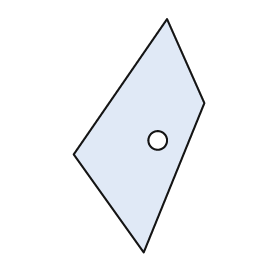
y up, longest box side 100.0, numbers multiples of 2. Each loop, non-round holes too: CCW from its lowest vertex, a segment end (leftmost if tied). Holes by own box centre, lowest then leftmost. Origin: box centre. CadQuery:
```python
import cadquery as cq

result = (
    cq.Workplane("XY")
    .moveTo(2.0, -50.0)
    .lineTo(28.0, 14.0)
    .lineTo(12.0, 50.0)
    .lineTo(-28.0, -8.0)
    .close()
    .moveTo(8.0, -2.0)
    .circle(4.0)
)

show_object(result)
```